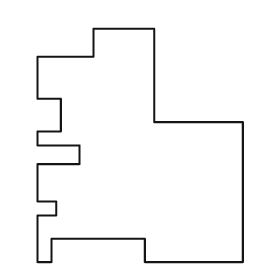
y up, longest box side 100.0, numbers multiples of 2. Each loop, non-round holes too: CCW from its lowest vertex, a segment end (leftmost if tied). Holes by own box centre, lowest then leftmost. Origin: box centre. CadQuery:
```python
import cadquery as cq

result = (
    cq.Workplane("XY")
    .moveTo(-44.0, -50.0)
    .lineTo(-38.0, -50.0)
    .lineTo(-38.0, -40.0)
    .lineTo(2.0, -40.0)
    .lineTo(2.0, -50.0)
    .lineTo(44.0, -50.0)
    .lineTo(44.0, 10.0)
    .lineTo(6.0, 10.0)
    .lineTo(6.0, 50.0)
    .lineTo(-20.0, 50.0)
    .lineTo(-20.0, 38.0)
    .lineTo(-44.0, 38.0)
    .lineTo(-44.0, 20.0)
    .lineTo(-34.0, 20.0)
    .lineTo(-34.0, 6.0)
    .lineTo(-44.0, 6.0)
    .lineTo(-44.0, 0.0)
    .lineTo(-26.0, 0.0)
    .lineTo(-26.0, -8.0)
    .lineTo(-44.0, -8.0)
    .lineTo(-44.0, -24.0)
    .lineTo(-36.0, -24.0)
    .lineTo(-36.0, -30.0)
    .lineTo(-44.0, -30.0)
    .close()
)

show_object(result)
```